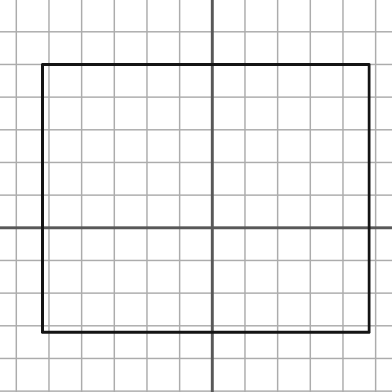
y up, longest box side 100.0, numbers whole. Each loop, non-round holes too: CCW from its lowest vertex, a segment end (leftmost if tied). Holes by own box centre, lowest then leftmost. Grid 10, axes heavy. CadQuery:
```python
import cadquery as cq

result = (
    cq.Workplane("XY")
    .moveTo(-52.0, -32.0)
    .lineTo(48.0, -32.0)
    .lineTo(48.0, 50.0)
    .lineTo(-52.0, 50.0)
    .close()
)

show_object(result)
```